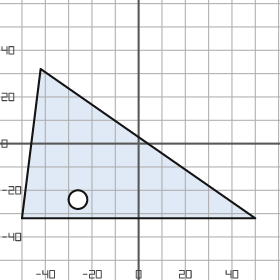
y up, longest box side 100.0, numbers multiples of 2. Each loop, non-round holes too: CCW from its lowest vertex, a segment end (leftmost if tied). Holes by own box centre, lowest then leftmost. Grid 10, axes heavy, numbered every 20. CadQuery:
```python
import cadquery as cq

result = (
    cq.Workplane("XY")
    .moveTo(-50.0, -32.0)
    .lineTo(50.0, -32.0)
    .lineTo(-42.0, 32.0)
    .close()
    .moveTo(-26.0, -24.0)
    .circle(4.0)
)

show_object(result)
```